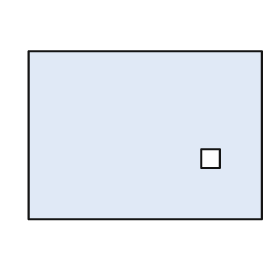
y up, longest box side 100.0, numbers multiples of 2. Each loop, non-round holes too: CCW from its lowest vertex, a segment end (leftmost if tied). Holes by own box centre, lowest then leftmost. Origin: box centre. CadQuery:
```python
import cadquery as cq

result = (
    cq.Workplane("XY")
    .moveTo(-50.0, -36.0)
    .lineTo(50.0, -36.0)
    .lineTo(50.0, 36.0)
    .lineTo(-50.0, 36.0)
    .close()
    .moveTo(24.0, -14.0)
    .lineTo(32.0, -14.0)
    .lineTo(32.0, -6.0)
    .lineTo(24.0, -6.0)
    .close()
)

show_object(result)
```